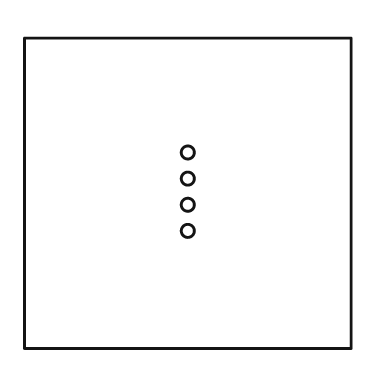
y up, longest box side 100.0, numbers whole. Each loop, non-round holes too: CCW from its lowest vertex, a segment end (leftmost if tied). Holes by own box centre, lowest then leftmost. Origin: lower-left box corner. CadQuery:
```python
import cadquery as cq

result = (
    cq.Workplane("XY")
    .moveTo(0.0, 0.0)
    .lineTo(100.0, 0.0)
    .lineTo(100.0, 95.0)
    .lineTo(0.0, 95.0)
    .close()
    .moveTo(50.0, 36.0)
    .circle(2.0)
    .moveTo(50.0, 44.0)
    .circle(2.0)
    .moveTo(50.0, 52.0)
    .circle(2.0)
    .moveTo(50.0, 60.0)
    .circle(2.0)
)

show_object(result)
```